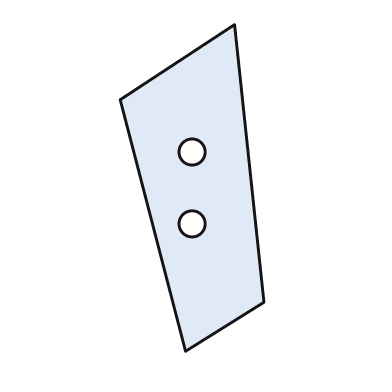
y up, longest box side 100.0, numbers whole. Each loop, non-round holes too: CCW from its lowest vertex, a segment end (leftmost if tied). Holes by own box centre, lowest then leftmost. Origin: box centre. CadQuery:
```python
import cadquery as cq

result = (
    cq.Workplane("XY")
    .moveTo(-2.0, -50.0)
    .lineTo(22.0, -35.0)
    .lineTo(13.0, 50.0)
    .lineTo(-22.0, 27.0)
    .close()
    .moveTo(0.0, -11.0)
    .circle(4.0)
    .moveTo(0.0, 11.0)
    .circle(4.0)
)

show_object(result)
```